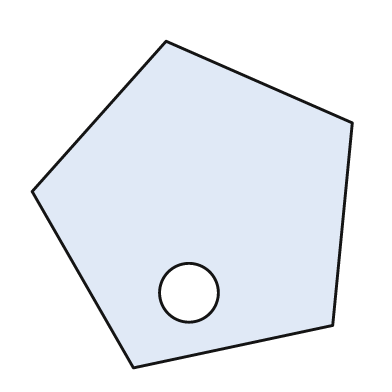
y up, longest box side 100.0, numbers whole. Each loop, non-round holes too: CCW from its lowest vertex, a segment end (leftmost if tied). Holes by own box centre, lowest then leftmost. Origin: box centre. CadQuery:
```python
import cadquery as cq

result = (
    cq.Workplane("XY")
    .moveTo(-18.0, -50.0)
    .lineTo(43.0, -37.0)
    .lineTo(49.0, 25.0)
    .lineTo(-8.0, 50.0)
    .lineTo(-49.0, 4.0)
    .close()
    .moveTo(-1.0, -27.0)
    .circle(9.0)
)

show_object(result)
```